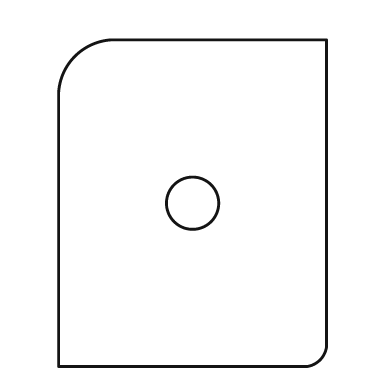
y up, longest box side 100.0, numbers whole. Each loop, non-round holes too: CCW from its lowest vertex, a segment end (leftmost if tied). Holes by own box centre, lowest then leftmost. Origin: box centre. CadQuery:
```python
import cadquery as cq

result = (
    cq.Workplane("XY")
    .moveTo(-41.0, -50.0)
    .lineTo(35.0, -50.0)
    .threePointArc((39.0, -48.0), (41.0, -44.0))
    .lineTo(41.0, 50.0)
    .lineTo(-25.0, 50.0)
    .threePointArc((-36.0, 45.0), (-41.0, 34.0))
    .close()
    .moveTo(0.0, 0.0)
    .circle(8.0)
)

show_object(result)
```